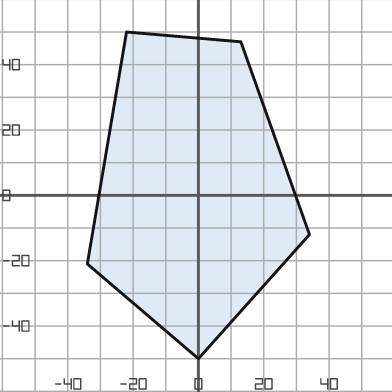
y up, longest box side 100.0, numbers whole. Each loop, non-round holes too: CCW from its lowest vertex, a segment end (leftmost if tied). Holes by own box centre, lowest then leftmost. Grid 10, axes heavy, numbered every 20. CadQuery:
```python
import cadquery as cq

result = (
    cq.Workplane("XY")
    .moveTo(0.0, -50.0)
    .lineTo(34.0, -12.0)
    .lineTo(13.0, 47.0)
    .lineTo(-22.0, 50.0)
    .lineTo(-34.0, -21.0)
    .close()
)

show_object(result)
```